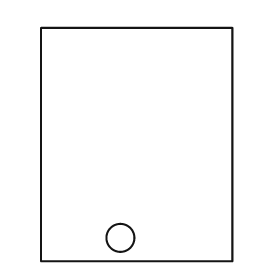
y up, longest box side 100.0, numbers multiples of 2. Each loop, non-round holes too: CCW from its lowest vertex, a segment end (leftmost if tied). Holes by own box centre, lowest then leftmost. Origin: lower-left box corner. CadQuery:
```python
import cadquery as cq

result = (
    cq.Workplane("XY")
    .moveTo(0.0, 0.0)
    .lineTo(82.0, 0.0)
    .lineTo(82.0, 100.0)
    .lineTo(0.0, 100.0)
    .close()
    .moveTo(34.0, 10.0)
    .circle(6.0)
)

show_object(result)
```